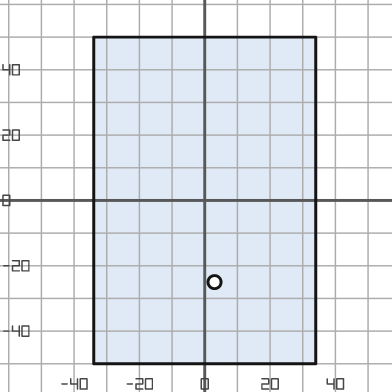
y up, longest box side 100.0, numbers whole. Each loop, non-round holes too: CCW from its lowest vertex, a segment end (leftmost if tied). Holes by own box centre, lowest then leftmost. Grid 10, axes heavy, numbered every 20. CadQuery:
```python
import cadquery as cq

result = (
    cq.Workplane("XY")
    .moveTo(-34.0, -50.0)
    .lineTo(34.0, -50.0)
    .lineTo(34.0, 50.0)
    .lineTo(-34.0, 50.0)
    .close()
    .moveTo(3.0, -25.0)
    .circle(2.0)
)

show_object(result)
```